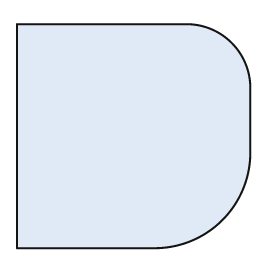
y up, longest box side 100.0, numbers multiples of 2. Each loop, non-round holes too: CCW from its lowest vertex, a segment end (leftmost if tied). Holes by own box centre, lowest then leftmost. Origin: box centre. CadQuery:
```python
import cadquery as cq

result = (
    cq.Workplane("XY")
    .moveTo(-50.0, -48.0)
    .lineTo(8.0, -48.0)
    .threePointArc((38.0, -36.0), (50.0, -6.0))
    .lineTo(50.0, 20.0)
    .threePointArc((42.0, 40.0), (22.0, 48.0))
    .lineTo(-50.0, 48.0)
    .close()
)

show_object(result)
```